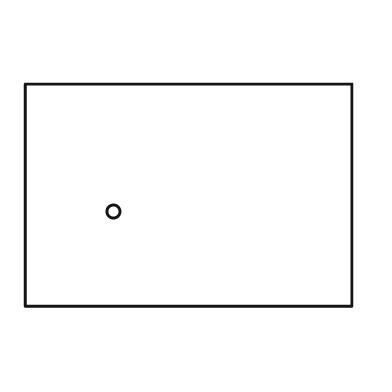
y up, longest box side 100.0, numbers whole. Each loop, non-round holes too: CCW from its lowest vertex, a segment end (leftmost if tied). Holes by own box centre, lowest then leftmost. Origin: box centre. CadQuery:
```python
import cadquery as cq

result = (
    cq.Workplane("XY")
    .moveTo(-50.0, -34.0)
    .lineTo(50.0, -34.0)
    .lineTo(50.0, 34.0)
    .lineTo(-50.0, 34.0)
    .close()
    .moveTo(-23.0, -5.0)
    .circle(2.0)
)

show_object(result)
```